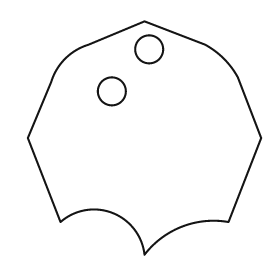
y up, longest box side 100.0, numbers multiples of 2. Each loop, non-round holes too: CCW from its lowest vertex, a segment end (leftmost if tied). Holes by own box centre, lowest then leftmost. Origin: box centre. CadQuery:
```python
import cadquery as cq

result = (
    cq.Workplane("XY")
    .moveTo(0.0, -50.0)
    .threePointArc((16.0, -38.0), (36.0, -36.0))
    .lineTo(50.0, 0.0)
    .lineTo(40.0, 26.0)
    .threePointArc((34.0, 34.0), (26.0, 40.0))
    .lineTo(0.0, 50.0)
    .lineTo(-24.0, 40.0)
    .threePointArc((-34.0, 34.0), (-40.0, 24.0))
    .lineTo(-50.0, 0.0)
    .lineTo(-36.0, -36.0)
    .threePointArc((-14.0, -32.0), (0.0, -50.0))
    .close()
    .moveTo(-14.0, 20.0)
    .circle(6.0)
    .moveTo(2.0, 38.0)
    .circle(6.0)
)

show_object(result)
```